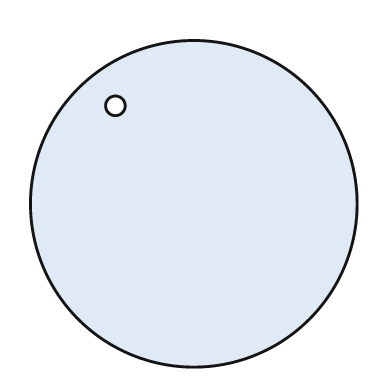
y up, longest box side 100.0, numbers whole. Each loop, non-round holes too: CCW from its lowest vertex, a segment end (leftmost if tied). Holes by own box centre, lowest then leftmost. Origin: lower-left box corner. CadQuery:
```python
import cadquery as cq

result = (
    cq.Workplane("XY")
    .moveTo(50.0, 50.0)
    .circle(50.0)
    .moveTo(26.0, 80.0)
    .circle(3.0)
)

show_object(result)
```